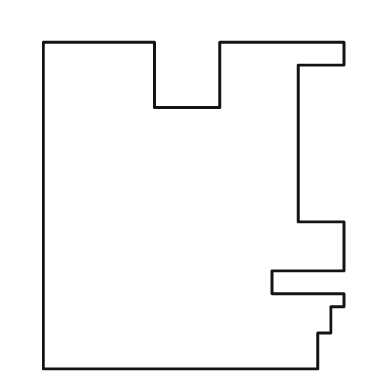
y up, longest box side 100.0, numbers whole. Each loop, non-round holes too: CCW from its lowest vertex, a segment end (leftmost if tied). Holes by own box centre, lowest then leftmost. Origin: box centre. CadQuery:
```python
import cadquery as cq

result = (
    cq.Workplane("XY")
    .moveTo(-46.0, -50.0)
    .lineTo(38.0, -50.0)
    .lineTo(38.0, -39.0)
    .lineTo(42.0, -39.0)
    .lineTo(42.0, -31.0)
    .lineTo(46.0, -31.0)
    .lineTo(46.0, -27.0)
    .lineTo(24.0, -27.0)
    .lineTo(24.0, -20.0)
    .lineTo(46.0, -20.0)
    .lineTo(46.0, -5.0)
    .lineTo(32.0, -5.0)
    .lineTo(32.0, 43.0)
    .lineTo(46.0, 43.0)
    .lineTo(46.0, 50.0)
    .lineTo(8.0, 50.0)
    .lineTo(8.0, 30.0)
    .lineTo(-12.0, 30.0)
    .lineTo(-12.0, 50.0)
    .lineTo(-46.0, 50.0)
    .close()
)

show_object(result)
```